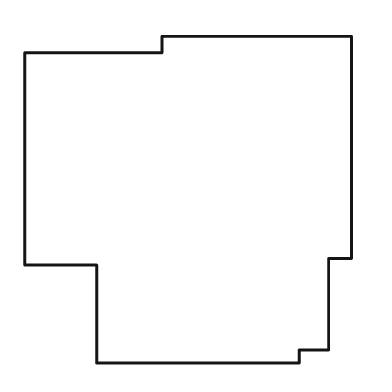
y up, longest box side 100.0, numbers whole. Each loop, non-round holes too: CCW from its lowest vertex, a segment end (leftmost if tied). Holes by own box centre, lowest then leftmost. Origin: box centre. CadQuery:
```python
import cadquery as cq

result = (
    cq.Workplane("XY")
    .moveTo(-28.0, -50.0)
    .lineTo(34.0, -50.0)
    .lineTo(34.0, -46.0)
    .lineTo(43.0, -46.0)
    .lineTo(43.0, -18.0)
    .lineTo(50.0, -18.0)
    .lineTo(50.0, 50.0)
    .lineTo(-8.0, 50.0)
    .lineTo(-8.0, 45.0)
    .lineTo(-50.0, 45.0)
    .lineTo(-50.0, -20.0)
    .lineTo(-28.0, -20.0)
    .close()
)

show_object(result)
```